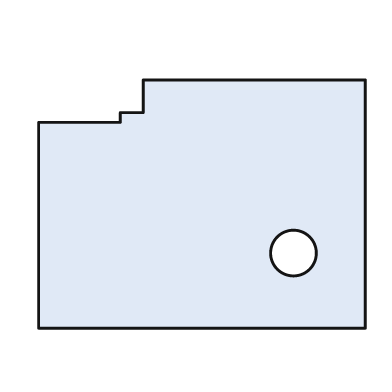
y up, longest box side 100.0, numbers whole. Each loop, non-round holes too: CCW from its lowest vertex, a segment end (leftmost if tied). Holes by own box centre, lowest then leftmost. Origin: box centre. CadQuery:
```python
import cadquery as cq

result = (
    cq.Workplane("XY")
    .moveTo(-50.0, -38.0)
    .lineTo(50.0, -38.0)
    .lineTo(50.0, 38.0)
    .lineTo(-18.0, 38.0)
    .lineTo(-18.0, 28.0)
    .lineTo(-25.0, 28.0)
    .lineTo(-25.0, 25.0)
    .lineTo(-50.0, 25.0)
    .close()
    .moveTo(28.0, -15.0)
    .circle(7.0)
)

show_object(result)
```